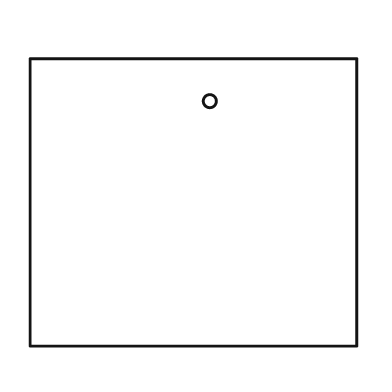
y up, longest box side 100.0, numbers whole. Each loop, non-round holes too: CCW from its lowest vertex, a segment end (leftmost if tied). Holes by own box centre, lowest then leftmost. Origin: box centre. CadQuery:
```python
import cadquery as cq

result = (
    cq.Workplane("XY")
    .moveTo(-50.0, -44.0)
    .lineTo(50.0, -44.0)
    .lineTo(50.0, 44.0)
    .lineTo(-50.0, 44.0)
    .close()
    .moveTo(5.0, 31.0)
    .circle(2.0)
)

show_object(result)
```